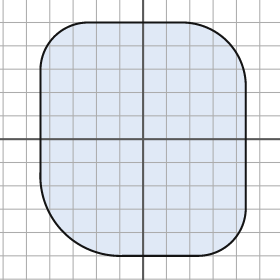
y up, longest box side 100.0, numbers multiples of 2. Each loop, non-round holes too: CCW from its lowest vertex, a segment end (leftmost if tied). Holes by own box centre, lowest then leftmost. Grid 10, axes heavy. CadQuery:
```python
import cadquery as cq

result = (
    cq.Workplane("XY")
    .moveTo(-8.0, -50.0)
    .lineTo(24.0, -50.0)
    .threePointArc((38.0, -44.0), (44.0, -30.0))
    .lineTo(44.0, 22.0)
    .threePointArc((36.0, 42.0), (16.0, 50.0))
    .lineTo(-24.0, 50.0)
    .threePointArc((-38.0, 44.0), (-44.0, 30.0))
    .lineTo(-44.0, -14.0)
    .threePointArc((-34.0, -40.0), (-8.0, -50.0))
    .close()
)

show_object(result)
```